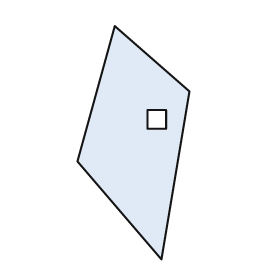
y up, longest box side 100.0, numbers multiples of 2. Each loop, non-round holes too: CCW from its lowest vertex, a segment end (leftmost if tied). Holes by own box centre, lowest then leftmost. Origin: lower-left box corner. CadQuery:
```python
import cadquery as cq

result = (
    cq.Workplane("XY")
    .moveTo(36.0, 0.0)
    .lineTo(48.0, 72.0)
    .lineTo(16.0, 100.0)
    .lineTo(0.0, 42.0)
    .close()
    .moveTo(30.0, 56.0)
    .lineTo(38.0, 56.0)
    .lineTo(38.0, 64.0)
    .lineTo(30.0, 64.0)
    .close()
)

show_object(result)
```